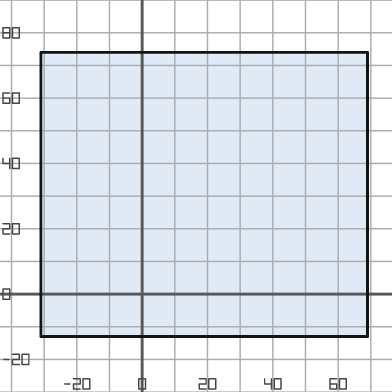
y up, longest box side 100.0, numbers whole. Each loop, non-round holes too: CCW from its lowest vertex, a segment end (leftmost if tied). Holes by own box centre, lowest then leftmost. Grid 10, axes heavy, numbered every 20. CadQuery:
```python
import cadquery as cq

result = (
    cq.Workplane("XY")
    .moveTo(-31.0, -13.0)
    .lineTo(69.0, -13.0)
    .lineTo(69.0, 74.0)
    .lineTo(-31.0, 74.0)
    .close()
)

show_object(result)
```